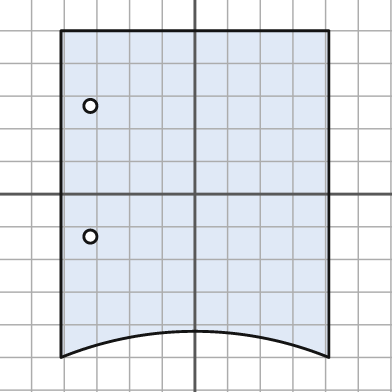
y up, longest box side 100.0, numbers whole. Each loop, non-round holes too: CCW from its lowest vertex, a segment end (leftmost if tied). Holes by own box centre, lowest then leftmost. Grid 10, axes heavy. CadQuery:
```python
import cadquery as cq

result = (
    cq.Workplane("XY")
    .moveTo(-41.0, -50.0)
    .threePointArc((0.0, -42.0), (41.0, -50.0))
    .lineTo(41.0, 50.0)
    .lineTo(-41.0, 50.0)
    .close()
    .moveTo(-32.0, -13.0)
    .circle(2.0)
    .moveTo(-32.0, 27.0)
    .circle(2.0)
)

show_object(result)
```